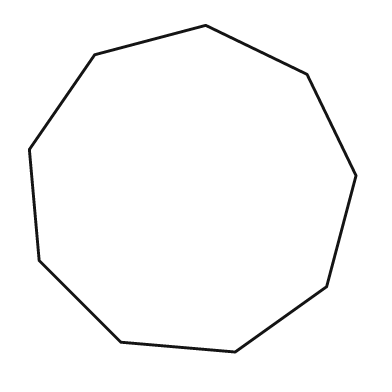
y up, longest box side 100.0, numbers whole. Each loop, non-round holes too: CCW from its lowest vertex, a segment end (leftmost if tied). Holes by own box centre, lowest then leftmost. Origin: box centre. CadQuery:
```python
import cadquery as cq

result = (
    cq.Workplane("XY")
    .moveTo(13.0, -50.0)
    .lineTo(41.0, -30.0)
    .lineTo(50.0, 4.0)
    .lineTo(35.0, 35.0)
    .lineTo(4.0, 50.0)
    .lineTo(-30.0, 41.0)
    .lineTo(-50.0, 12.0)
    .lineTo(-47.0, -22.0)
    .lineTo(-22.0, -47.0)
    .close()
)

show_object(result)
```